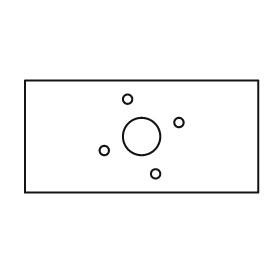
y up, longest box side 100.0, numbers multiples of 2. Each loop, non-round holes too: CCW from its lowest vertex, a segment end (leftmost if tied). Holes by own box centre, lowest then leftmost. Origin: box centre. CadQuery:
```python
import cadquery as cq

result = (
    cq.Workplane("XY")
    .moveTo(-50.0, -24.0)
    .lineTo(50.0, -24.0)
    .lineTo(50.0, 24.0)
    .lineTo(-50.0, 24.0)
    .close()
    .moveTo(6.0, -16.0)
    .circle(2.0)
    .moveTo(-16.0, -6.0)
    .circle(2.0)
    .moveTo(0.0, 0.0)
    .circle(8.0)
    .moveTo(16.0, 6.0)
    .circle(2.0)
    .moveTo(-6.0, 16.0)
    .circle(2.0)
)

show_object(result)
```